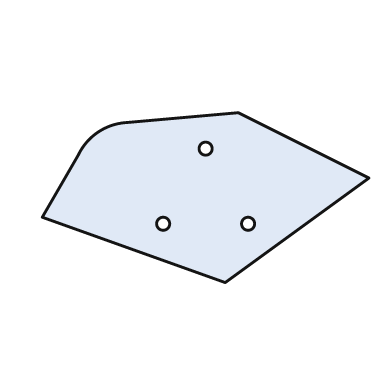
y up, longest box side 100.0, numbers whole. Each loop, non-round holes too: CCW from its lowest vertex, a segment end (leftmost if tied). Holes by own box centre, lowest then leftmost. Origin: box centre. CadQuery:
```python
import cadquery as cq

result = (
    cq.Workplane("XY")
    .moveTo(6.0, -26.0)
    .lineTo(50.0, 6.0)
    .lineTo(10.0, 26.0)
    .lineTo(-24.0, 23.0)
    .threePointArc((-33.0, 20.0), (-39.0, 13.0))
    .lineTo(-50.0, -6.0)
    .close()
    .moveTo(-13.0, -8.0)
    .circle(2.0)
    .moveTo(13.0, -8.0)
    .circle(2.0)
    .moveTo(0.0, 15.0)
    .circle(2.0)
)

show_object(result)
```